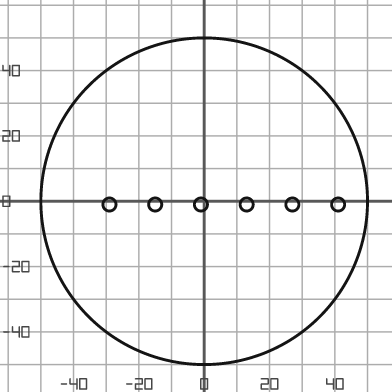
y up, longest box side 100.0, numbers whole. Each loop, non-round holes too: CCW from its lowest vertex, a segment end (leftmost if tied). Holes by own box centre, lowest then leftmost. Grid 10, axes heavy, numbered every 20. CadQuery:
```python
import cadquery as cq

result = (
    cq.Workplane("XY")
    .moveTo(0.0, 0.0)
    .circle(50.0)
    .moveTo(-29.0, -1.0)
    .circle(2.0)
    .moveTo(-15.0, -1.0)
    .circle(2.0)
    .moveTo(-1.0, -1.0)
    .circle(2.0)
    .moveTo(13.0, -1.0)
    .circle(2.0)
    .moveTo(27.0, -1.0)
    .circle(2.0)
    .moveTo(41.0, -1.0)
    .circle(2.0)
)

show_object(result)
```